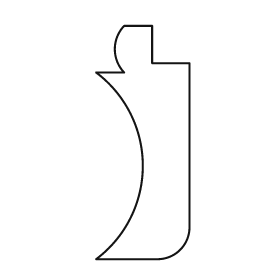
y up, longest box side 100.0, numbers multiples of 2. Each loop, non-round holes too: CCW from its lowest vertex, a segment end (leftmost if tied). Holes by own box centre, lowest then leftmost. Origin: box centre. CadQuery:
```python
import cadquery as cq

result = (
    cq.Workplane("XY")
    .moveTo(-20.0, -50.0)
    .lineTo(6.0, -50.0)
    .threePointArc((16.0, -46.0), (20.0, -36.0))
    .lineTo(20.0, 34.0)
    .lineTo(4.0, 34.0)
    .lineTo(4.0, 50.0)
    .lineTo(-8.0, 50.0)
    .threePointArc((-12.0, 40.0), (-8.0, 30.0))
    .lineTo(-20.0, 30.0)
    .threePointArc((0.0, -10.0), (-20.0, -50.0))
    .close()
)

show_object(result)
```